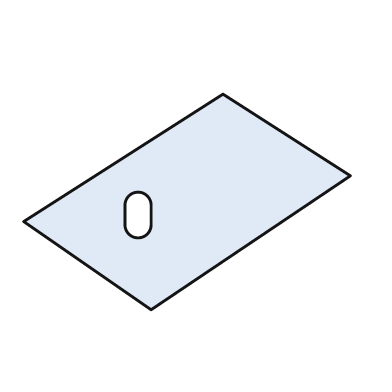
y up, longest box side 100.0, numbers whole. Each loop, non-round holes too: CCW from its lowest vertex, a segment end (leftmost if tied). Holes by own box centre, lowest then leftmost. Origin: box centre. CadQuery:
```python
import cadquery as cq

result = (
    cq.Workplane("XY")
    .moveTo(-11.0, -33.0)
    .lineTo(50.0, 8.0)
    .lineTo(11.0, 33.0)
    .lineTo(-50.0, -6.0)
    .close()
    .moveTo(-19.0, -7.0)
    .threePointArc((-15.0, -11.0), (-11.0, -7.0))
    .lineTo(-11.0, -1.0)
    .threePointArc((-15.0, 3.0), (-19.0, -1.0))
    .close()
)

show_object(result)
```